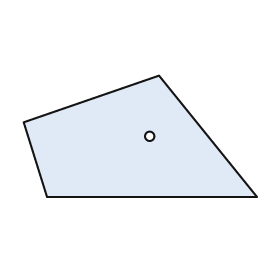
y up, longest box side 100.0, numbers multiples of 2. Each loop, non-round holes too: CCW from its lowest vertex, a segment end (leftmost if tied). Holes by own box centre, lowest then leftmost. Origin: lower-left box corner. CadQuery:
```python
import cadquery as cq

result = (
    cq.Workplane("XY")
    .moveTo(10.0, 0.0)
    .lineTo(100.0, 0.0)
    .lineTo(58.0, 52.0)
    .lineTo(0.0, 32.0)
    .close()
    .moveTo(54.0, 26.0)
    .circle(2.0)
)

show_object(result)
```